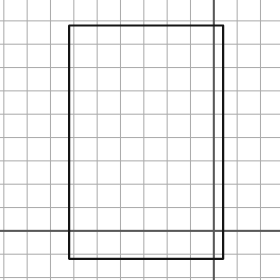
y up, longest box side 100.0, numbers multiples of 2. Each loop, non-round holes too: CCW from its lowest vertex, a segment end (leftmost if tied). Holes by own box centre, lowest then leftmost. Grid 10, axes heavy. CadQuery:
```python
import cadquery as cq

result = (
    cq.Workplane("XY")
    .moveTo(-62.0, -12.0)
    .lineTo(4.0, -12.0)
    .lineTo(4.0, 88.0)
    .lineTo(-62.0, 88.0)
    .close()
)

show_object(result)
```